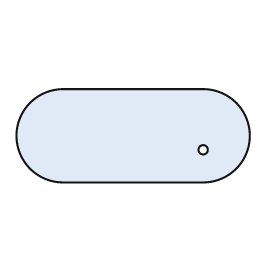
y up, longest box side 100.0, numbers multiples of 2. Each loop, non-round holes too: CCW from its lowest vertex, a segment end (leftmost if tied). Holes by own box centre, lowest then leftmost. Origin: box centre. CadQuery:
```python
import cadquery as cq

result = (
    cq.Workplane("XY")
    .moveTo(-30.0, -20.0)
    .lineTo(30.0, -20.0)
    .threePointArc((50.0, 0.0), (30.0, 20.0))
    .lineTo(-30.0, 20.0)
    .threePointArc((-50.0, 0.0), (-30.0, -20.0))
    .close()
    .moveTo(30.0, -6.0)
    .circle(2.0)
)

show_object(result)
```